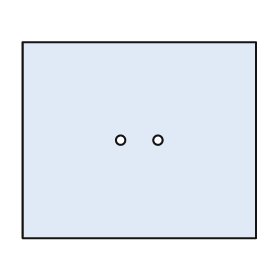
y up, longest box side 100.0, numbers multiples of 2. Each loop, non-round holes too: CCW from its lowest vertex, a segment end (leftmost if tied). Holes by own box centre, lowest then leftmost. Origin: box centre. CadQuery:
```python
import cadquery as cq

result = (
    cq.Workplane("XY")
    .moveTo(-50.0, -42.0)
    .lineTo(50.0, -42.0)
    .lineTo(50.0, 42.0)
    .lineTo(-50.0, 42.0)
    .close()
    .moveTo(-8.0, 0.0)
    .circle(2.0)
    .moveTo(8.0, 0.0)
    .circle(2.0)
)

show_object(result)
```